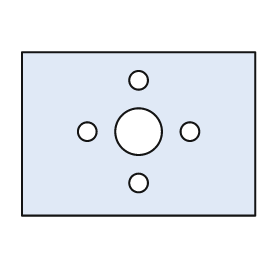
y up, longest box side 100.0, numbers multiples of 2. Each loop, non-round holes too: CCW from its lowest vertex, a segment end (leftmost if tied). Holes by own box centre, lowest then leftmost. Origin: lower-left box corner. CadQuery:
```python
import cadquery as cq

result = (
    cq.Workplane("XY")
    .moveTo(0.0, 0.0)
    .lineTo(100.0, 0.0)
    .lineTo(100.0, 70.0)
    .lineTo(0.0, 70.0)
    .close()
    .moveTo(50.0, 14.0)
    .circle(4.0)
    .moveTo(28.0, 36.0)
    .circle(4.0)
    .moveTo(50.0, 36.0)
    .circle(10.0)
    .moveTo(72.0, 36.0)
    .circle(4.0)
    .moveTo(50.0, 58.0)
    .circle(4.0)
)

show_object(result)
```